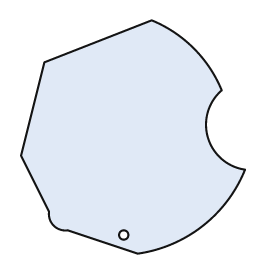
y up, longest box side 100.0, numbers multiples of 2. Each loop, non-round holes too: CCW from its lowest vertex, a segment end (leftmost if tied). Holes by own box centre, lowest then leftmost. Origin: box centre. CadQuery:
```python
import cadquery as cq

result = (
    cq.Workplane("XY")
    .moveTo(2.0, -50.0)
    .threePointArc((30.0, -38.0), (48.0, -14.0))
    .threePointArc((32.0, 0.0), (38.0, 20.0))
    .threePointArc((26.0, 38.0), (8.0, 50.0))
    .lineTo(-38.0, 32.0)
    .lineTo(-48.0, -8.0)
    .lineTo(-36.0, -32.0)
    .threePointArc((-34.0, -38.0), (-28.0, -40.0))
    .close()
    .moveTo(-4.0, -42.0)
    .circle(2.0)
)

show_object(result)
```